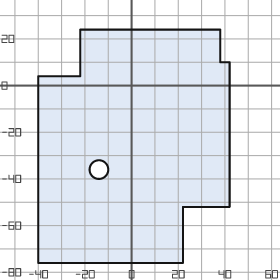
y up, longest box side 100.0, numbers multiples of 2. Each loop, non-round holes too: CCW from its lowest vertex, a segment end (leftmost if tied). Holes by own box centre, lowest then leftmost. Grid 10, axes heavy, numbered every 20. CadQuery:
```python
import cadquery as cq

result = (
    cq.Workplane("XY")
    .moveTo(-40.0, -76.0)
    .lineTo(22.0, -76.0)
    .lineTo(22.0, -52.0)
    .lineTo(42.0, -52.0)
    .lineTo(42.0, 10.0)
    .lineTo(38.0, 10.0)
    .lineTo(38.0, 24.0)
    .lineTo(-22.0, 24.0)
    .lineTo(-22.0, 4.0)
    .lineTo(-40.0, 4.0)
    .close()
    .moveTo(-14.0, -36.0)
    .circle(4.0)
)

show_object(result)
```